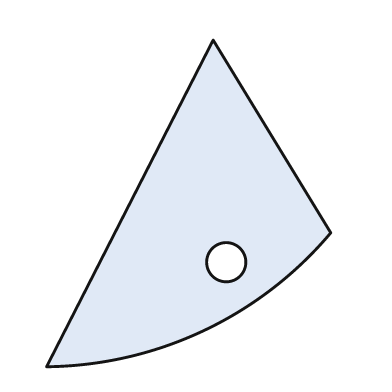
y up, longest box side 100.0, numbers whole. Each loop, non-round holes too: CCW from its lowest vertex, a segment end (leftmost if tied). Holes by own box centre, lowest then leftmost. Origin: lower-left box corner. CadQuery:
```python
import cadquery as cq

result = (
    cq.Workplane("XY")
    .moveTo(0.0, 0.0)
    .threePointArc((48.0, 11.0), (87.0, 41.0))
    .lineTo(51.0, 100.0)
    .close()
    .moveTo(55.0, 32.0)
    .circle(6.0)
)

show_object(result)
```